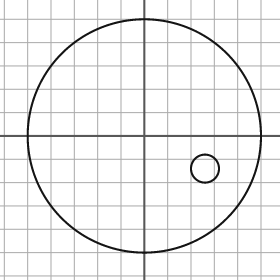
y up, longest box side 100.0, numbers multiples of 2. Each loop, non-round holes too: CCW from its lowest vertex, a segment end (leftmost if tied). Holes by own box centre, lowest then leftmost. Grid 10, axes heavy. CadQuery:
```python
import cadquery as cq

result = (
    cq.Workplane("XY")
    .moveTo(0.0, 0.0)
    .circle(50.0)
    .moveTo(26.0, -14.0)
    .circle(6.0)
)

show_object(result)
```